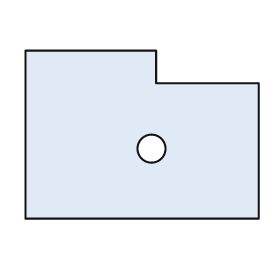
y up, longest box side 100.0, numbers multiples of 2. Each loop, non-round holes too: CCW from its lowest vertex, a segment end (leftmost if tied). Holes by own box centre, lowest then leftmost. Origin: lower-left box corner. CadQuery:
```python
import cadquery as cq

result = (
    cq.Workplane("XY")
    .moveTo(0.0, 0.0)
    .lineTo(100.0, 0.0)
    .lineTo(100.0, 58.0)
    .lineTo(56.0, 58.0)
    .lineTo(56.0, 72.0)
    .lineTo(0.0, 72.0)
    .close()
    .moveTo(54.0, 30.0)
    .circle(6.0)
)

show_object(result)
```